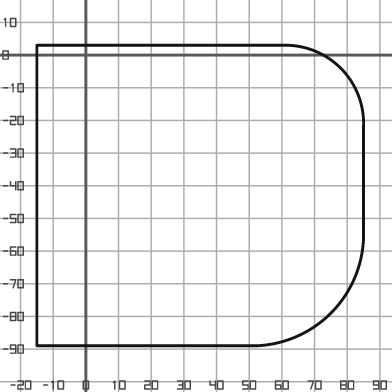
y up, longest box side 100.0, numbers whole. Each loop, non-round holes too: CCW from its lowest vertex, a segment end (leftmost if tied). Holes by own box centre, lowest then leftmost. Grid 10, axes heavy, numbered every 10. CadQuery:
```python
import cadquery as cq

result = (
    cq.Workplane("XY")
    .moveTo(-15.0, -89.0)
    .lineTo(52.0, -89.0)
    .threePointArc((75.0, -79.0), (85.0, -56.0))
    .lineTo(85.0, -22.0)
    .threePointArc((78.0, -4.0), (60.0, 3.0))
    .lineTo(-15.0, 3.0)
    .close()
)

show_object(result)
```